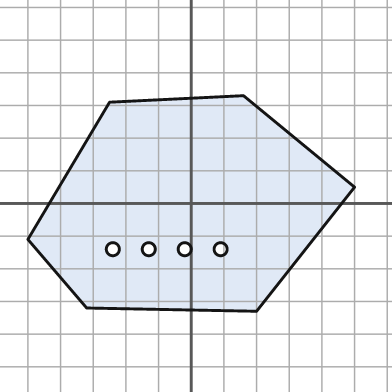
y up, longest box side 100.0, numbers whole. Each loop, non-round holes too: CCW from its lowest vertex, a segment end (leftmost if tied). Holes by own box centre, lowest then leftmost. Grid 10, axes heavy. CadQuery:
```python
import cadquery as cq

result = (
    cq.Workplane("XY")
    .moveTo(20.0, -33.0)
    .lineTo(50.0, 5.0)
    .lineTo(16.0, 33.0)
    .lineTo(-25.0, 31.0)
    .lineTo(-50.0, -11.0)
    .lineTo(-32.0, -32.0)
    .close()
    .moveTo(-24.0, -14.0)
    .circle(2.0)
    .moveTo(-13.0, -14.0)
    .circle(2.0)
    .moveTo(-2.0, -14.0)
    .circle(2.0)
    .moveTo(9.0, -14.0)
    .circle(2.0)
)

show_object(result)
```